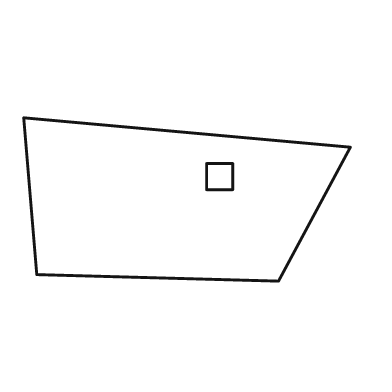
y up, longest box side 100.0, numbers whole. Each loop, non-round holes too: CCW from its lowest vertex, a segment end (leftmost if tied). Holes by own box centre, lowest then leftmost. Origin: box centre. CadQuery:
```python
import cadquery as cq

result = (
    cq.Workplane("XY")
    .moveTo(28.0, -25.0)
    .lineTo(50.0, 16.0)
    .lineTo(-50.0, 25.0)
    .lineTo(-46.0, -23.0)
    .close()
    .moveTo(6.0, 3.0)
    .lineTo(14.0, 3.0)
    .lineTo(14.0, 11.0)
    .lineTo(6.0, 11.0)
    .close()
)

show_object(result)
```